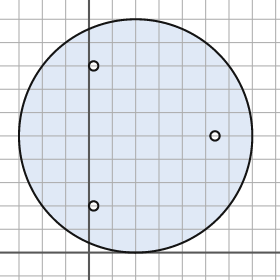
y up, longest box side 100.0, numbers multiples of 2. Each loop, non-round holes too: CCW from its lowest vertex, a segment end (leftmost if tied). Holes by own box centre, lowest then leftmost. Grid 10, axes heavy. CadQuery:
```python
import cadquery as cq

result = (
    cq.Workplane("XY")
    .moveTo(20.0, 50.0)
    .circle(50.0)
    .moveTo(2.0, 20.0)
    .circle(2.0)
    .moveTo(54.0, 50.0)
    .circle(2.0)
    .moveTo(2.0, 80.0)
    .circle(2.0)
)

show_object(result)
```